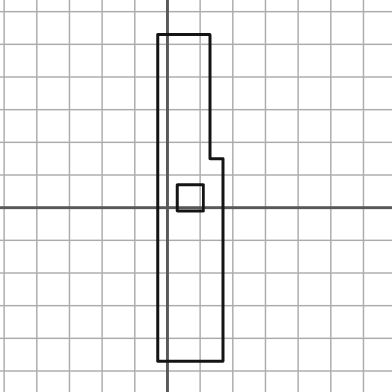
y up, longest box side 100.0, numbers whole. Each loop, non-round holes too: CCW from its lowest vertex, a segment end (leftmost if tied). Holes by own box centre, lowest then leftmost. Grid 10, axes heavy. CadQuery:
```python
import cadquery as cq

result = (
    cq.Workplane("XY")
    .moveTo(-3.0, -47.0)
    .lineTo(17.0, -47.0)
    .lineTo(17.0, 15.0)
    .lineTo(13.0, 15.0)
    .lineTo(13.0, 53.0)
    .lineTo(-3.0, 53.0)
    .close()
    .moveTo(3.0, -1.0)
    .lineTo(11.0, -1.0)
    .lineTo(11.0, 7.0)
    .lineTo(3.0, 7.0)
    .close()
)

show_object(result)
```